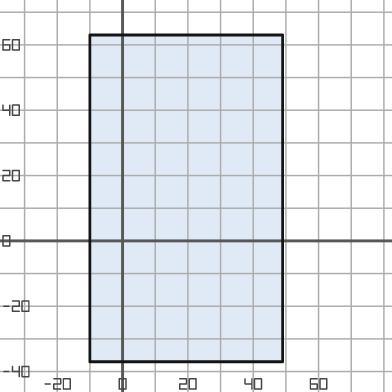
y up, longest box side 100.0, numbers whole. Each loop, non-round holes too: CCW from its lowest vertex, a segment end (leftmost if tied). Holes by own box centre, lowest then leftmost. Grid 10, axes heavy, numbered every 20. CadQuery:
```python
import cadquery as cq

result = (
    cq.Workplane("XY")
    .moveTo(-10.0, -37.0)
    .lineTo(49.0, -37.0)
    .lineTo(49.0, 63.0)
    .lineTo(-10.0, 63.0)
    .close()
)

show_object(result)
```